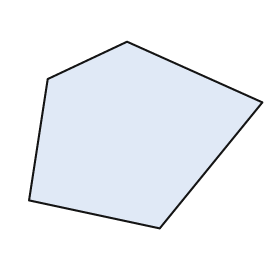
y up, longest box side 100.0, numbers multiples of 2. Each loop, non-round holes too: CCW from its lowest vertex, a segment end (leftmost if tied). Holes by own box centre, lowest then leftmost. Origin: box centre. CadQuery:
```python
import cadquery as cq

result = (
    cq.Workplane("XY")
    .moveTo(6.0, -40.0)
    .lineTo(50.0, 14.0)
    .lineTo(-8.0, 40.0)
    .lineTo(-42.0, 24.0)
    .lineTo(-50.0, -28.0)
    .close()
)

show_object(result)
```